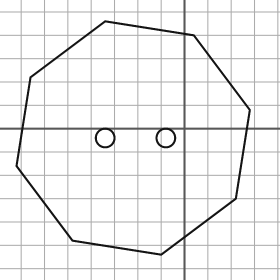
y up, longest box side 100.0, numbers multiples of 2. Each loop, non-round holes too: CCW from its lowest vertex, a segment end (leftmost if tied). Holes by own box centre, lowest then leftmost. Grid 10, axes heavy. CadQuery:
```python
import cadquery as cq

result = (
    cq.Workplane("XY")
    .moveTo(-10.0, -54.0)
    .lineTo(22.0, -30.0)
    .lineTo(28.0, 8.0)
    .lineTo(4.0, 40.0)
    .lineTo(-34.0, 46.0)
    .lineTo(-66.0, 22.0)
    .lineTo(-72.0, -16.0)
    .lineTo(-48.0, -48.0)
    .close()
    .moveTo(-34.0, -4.0)
    .circle(4.0)
    .moveTo(-8.0, -4.0)
    .circle(4.0)
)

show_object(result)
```